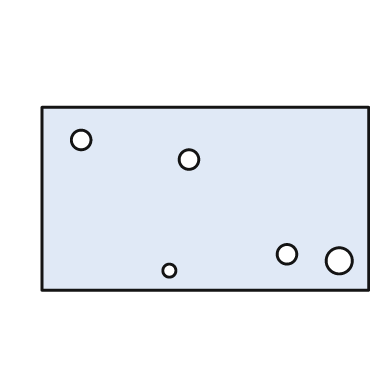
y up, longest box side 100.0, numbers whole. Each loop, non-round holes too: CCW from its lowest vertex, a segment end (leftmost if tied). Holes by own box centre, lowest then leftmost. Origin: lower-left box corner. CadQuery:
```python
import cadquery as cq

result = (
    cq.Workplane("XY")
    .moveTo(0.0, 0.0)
    .lineTo(100.0, 0.0)
    .lineTo(100.0, 56.0)
    .lineTo(0.0, 56.0)
    .close()
    .moveTo(39.0, 6.0)
    .circle(2.0)
    .moveTo(91.0, 9.0)
    .circle(4.0)
    .moveTo(75.0, 11.0)
    .circle(3.0)
    .moveTo(45.0, 40.0)
    .circle(3.0)
    .moveTo(12.0, 46.0)
    .circle(3.0)
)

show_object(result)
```